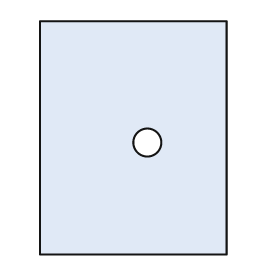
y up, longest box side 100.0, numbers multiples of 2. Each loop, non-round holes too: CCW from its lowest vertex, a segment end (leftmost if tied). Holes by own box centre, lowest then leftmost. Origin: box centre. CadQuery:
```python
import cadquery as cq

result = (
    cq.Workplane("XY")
    .moveTo(-40.0, -50.0)
    .lineTo(40.0, -50.0)
    .lineTo(40.0, 50.0)
    .lineTo(-40.0, 50.0)
    .close()
    .moveTo(6.0, -2.0)
    .circle(6.0)
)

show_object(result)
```